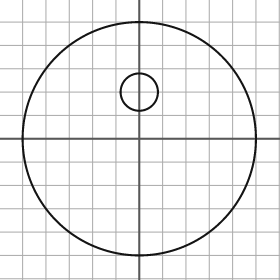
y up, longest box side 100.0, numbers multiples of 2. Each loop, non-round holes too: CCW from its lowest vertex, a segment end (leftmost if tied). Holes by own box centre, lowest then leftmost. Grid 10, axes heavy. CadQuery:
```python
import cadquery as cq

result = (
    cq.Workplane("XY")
    .moveTo(0.0, 0.0)
    .circle(50.0)
    .moveTo(0.0, 20.0)
    .circle(8.0)
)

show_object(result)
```